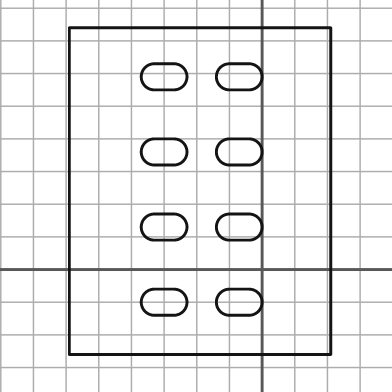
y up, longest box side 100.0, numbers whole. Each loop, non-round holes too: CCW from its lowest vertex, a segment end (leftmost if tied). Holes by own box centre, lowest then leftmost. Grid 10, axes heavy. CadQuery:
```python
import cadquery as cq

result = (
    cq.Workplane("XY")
    .moveTo(-59.0, -26.0)
    .lineTo(21.0, -26.0)
    .lineTo(21.0, 74.0)
    .lineTo(-59.0, 74.0)
    .close()
    .moveTo(-33.0, -14.0)
    .lineTo(-27.0, -14.0)
    .threePointArc((-23.0, -10.0), (-27.0, -6.0))
    .lineTo(-33.0, -6.0)
    .threePointArc((-37.0, -10.0), (-33.0, -14.0))
    .close()
    .moveTo(-10.0, -14.0)
    .lineTo(-4.0, -14.0)
    .threePointArc((0.0, -10.0), (-4.0, -6.0))
    .lineTo(-10.0, -6.0)
    .threePointArc((-14.0, -10.0), (-10.0, -14.0))
    .close()
    .moveTo(-33.0, 9.0)
    .lineTo(-27.0, 9.0)
    .threePointArc((-23.0, 13.0), (-27.0, 17.0))
    .lineTo(-33.0, 17.0)
    .threePointArc((-37.0, 13.0), (-33.0, 9.0))
    .close()
    .moveTo(-10.0, 9.0)
    .lineTo(-4.0, 9.0)
    .threePointArc((0.0, 13.0), (-4.0, 17.0))
    .lineTo(-10.0, 17.0)
    .threePointArc((-14.0, 13.0), (-10.0, 9.0))
    .close()
    .moveTo(-33.0, 32.0)
    .lineTo(-27.0, 32.0)
    .threePointArc((-23.0, 36.0), (-27.0, 40.0))
    .lineTo(-33.0, 40.0)
    .threePointArc((-37.0, 36.0), (-33.0, 32.0))
    .close()
    .moveTo(-10.0, 32.0)
    .lineTo(-4.0, 32.0)
    .threePointArc((0.0, 36.0), (-4.0, 40.0))
    .lineTo(-10.0, 40.0)
    .threePointArc((-14.0, 36.0), (-10.0, 32.0))
    .close()
    .moveTo(-33.0, 55.0)
    .lineTo(-27.0, 55.0)
    .threePointArc((-23.0, 59.0), (-27.0, 63.0))
    .lineTo(-33.0, 63.0)
    .threePointArc((-37.0, 59.0), (-33.0, 55.0))
    .close()
    .moveTo(-10.0, 55.0)
    .lineTo(-4.0, 55.0)
    .threePointArc((0.0, 59.0), (-4.0, 63.0))
    .lineTo(-10.0, 63.0)
    .threePointArc((-14.0, 59.0), (-10.0, 55.0))
    .close()
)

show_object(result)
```